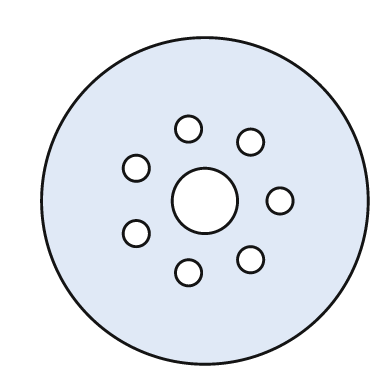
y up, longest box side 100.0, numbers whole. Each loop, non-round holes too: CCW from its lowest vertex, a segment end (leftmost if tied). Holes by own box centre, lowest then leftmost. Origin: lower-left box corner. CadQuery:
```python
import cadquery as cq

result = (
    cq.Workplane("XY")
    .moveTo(50.0, 50.0)
    .circle(50.0)
    .moveTo(45.0, 28.0)
    .circle(4.0)
    .moveTo(64.0, 32.0)
    .circle(4.0)
    .moveTo(29.0, 40.0)
    .circle(4.0)
    .moveTo(50.0, 50.0)
    .circle(10.0)
    .moveTo(73.0, 50.0)
    .circle(4.0)
    .moveTo(29.0, 60.0)
    .circle(4.0)
    .moveTo(64.0, 68.0)
    .circle(4.0)
    .moveTo(45.0, 72.0)
    .circle(4.0)
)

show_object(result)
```